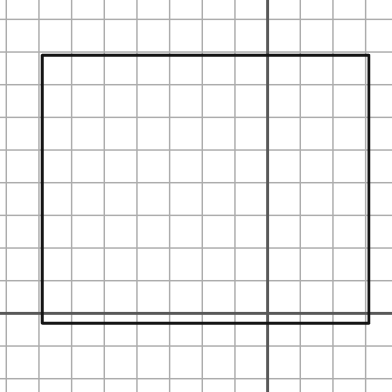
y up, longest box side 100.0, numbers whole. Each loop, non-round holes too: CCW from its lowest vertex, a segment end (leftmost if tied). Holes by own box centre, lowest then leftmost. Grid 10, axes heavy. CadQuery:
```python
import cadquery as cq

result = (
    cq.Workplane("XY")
    .moveTo(-69.0, -3.0)
    .lineTo(31.0, -3.0)
    .lineTo(31.0, 79.0)
    .lineTo(-69.0, 79.0)
    .close()
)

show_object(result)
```